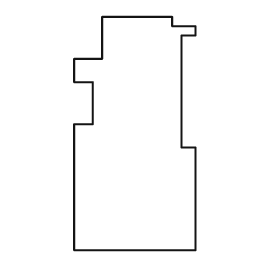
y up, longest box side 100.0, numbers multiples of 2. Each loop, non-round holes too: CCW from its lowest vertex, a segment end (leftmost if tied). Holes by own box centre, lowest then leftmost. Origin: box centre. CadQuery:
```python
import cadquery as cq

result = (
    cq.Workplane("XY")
    .moveTo(-26.0, -50.0)
    .lineTo(26.0, -50.0)
    .lineTo(26.0, -6.0)
    .lineTo(20.0, -6.0)
    .lineTo(20.0, 42.0)
    .lineTo(26.0, 42.0)
    .lineTo(26.0, 46.0)
    .lineTo(16.0, 46.0)
    .lineTo(16.0, 50.0)
    .lineTo(-14.0, 50.0)
    .lineTo(-14.0, 32.0)
    .lineTo(-26.0, 32.0)
    .lineTo(-26.0, 22.0)
    .lineTo(-18.0, 22.0)
    .lineTo(-18.0, 4.0)
    .lineTo(-26.0, 4.0)
    .close()
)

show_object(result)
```